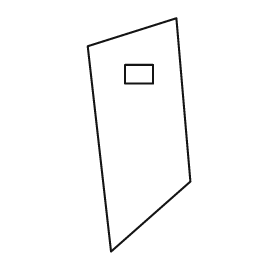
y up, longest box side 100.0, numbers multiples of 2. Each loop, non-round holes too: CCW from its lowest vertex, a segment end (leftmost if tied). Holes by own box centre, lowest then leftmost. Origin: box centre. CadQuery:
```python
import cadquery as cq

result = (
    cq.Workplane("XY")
    .moveTo(-12.0, -50.0)
    .lineTo(22.0, -20.0)
    .lineTo(16.0, 50.0)
    .lineTo(-22.0, 38.0)
    .close()
    .moveTo(-6.0, 22.0)
    .lineTo(6.0, 22.0)
    .lineTo(6.0, 30.0)
    .lineTo(-6.0, 30.0)
    .close()
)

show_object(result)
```